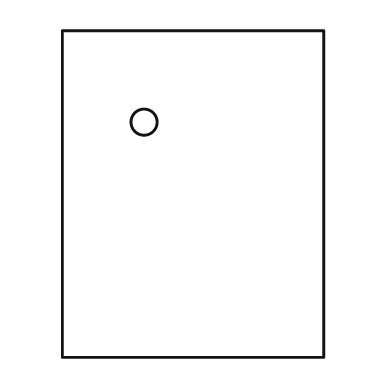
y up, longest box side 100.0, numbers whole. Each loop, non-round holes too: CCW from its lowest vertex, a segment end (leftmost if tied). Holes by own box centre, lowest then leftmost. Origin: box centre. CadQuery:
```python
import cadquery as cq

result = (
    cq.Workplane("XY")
    .moveTo(-40.0, -50.0)
    .lineTo(40.0, -50.0)
    .lineTo(40.0, 50.0)
    .lineTo(-40.0, 50.0)
    .close()
    .moveTo(-15.0, 22.0)
    .circle(4.0)
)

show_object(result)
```